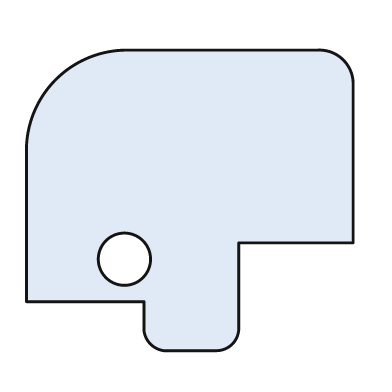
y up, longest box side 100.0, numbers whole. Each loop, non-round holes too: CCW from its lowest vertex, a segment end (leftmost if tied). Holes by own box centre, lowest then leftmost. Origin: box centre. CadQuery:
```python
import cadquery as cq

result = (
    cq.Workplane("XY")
    .moveTo(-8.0, -46.0)
    .lineTo(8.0, -46.0)
    .threePointArc((13.0, -44.0), (15.0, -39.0))
    .lineTo(15.0, -13.0)
    .lineTo(50.0, -13.0)
    .lineTo(50.0, 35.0)
    .threePointArc((47.0, 43.0), (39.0, 46.0))
    .lineTo(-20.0, 46.0)
    .threePointArc((-41.0, 37.0), (-50.0, 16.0))
    .lineTo(-50.0, -31.0)
    .lineTo(-14.0, -31.0)
    .lineTo(-14.0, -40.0)
    .threePointArc((-12.0, -44.0), (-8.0, -46.0))
    .close()
    .moveTo(-20.0, -18.0)
    .circle(8.0)
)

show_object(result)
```